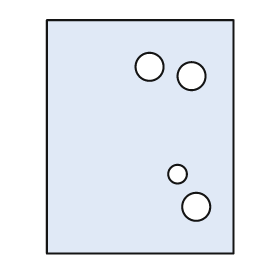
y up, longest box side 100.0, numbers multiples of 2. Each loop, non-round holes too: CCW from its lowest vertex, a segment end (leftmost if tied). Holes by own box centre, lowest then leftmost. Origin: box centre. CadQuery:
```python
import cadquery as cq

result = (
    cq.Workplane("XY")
    .moveTo(-40.0, -50.0)
    .lineTo(40.0, -50.0)
    .lineTo(40.0, 50.0)
    .lineTo(-40.0, 50.0)
    .close()
    .moveTo(24.0, -30.0)
    .circle(6.0)
    .moveTo(16.0, -16.0)
    .circle(4.0)
    .moveTo(22.0, 26.0)
    .circle(6.0)
    .moveTo(4.0, 30.0)
    .circle(6.0)
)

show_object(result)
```